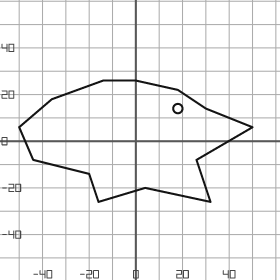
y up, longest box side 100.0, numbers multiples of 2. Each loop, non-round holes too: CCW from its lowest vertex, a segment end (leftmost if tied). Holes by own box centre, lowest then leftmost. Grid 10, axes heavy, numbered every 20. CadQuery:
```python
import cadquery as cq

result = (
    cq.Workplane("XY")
    .moveTo(-16.0, -26.0)
    .lineTo(4.0, -20.0)
    .lineTo(32.0, -26.0)
    .lineTo(26.0, -8.0)
    .lineTo(50.0, 6.0)
    .lineTo(30.0, 14.0)
    .lineTo(18.0, 22.0)
    .lineTo(0.0, 26.0)
    .lineTo(-14.0, 26.0)
    .lineTo(-36.0, 18.0)
    .lineTo(-50.0, 6.0)
    .lineTo(-44.0, -8.0)
    .lineTo(-20.0, -14.0)
    .close()
    .moveTo(18.0, 14.0)
    .circle(2.0)
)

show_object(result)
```